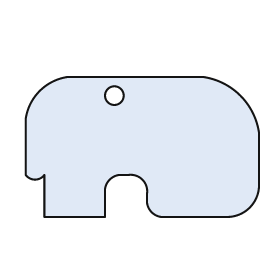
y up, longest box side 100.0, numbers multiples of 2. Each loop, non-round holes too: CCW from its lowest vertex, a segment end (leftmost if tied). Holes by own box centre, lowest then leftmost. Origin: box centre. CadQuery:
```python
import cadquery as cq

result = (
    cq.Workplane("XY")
    .moveTo(-42.0, -30.0)
    .lineTo(-16.0, -30.0)
    .lineTo(-16.0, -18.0)
    .threePointArc((-14.0, -14.0), (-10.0, -12.0))
    .lineTo(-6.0, -12.0)
    .threePointArc((0.0, -14.0), (2.0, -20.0))
    .lineTo(2.0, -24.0)
    .threePointArc((4.0, -28.0), (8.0, -30.0))
    .lineTo(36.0, -30.0)
    .threePointArc((46.0, -26.0), (50.0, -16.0))
    .lineTo(50.0, 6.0)
    .threePointArc((42.0, 22.0), (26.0, 30.0))
    .lineTo(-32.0, 30.0)
    .threePointArc((-44.0, 24.0), (-50.0, 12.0))
    .lineTo(-50.0, -12.0)
    .threePointArc((-46.0, -14.0), (-42.0, -12.0))
    .close()
    .moveTo(-12.0, 22.0)
    .circle(4.0)
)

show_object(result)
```